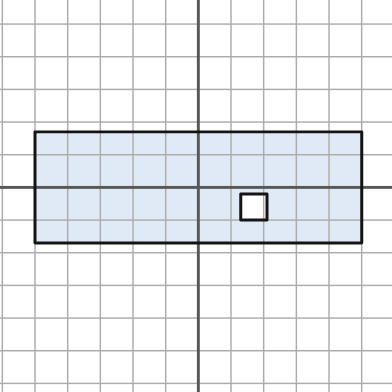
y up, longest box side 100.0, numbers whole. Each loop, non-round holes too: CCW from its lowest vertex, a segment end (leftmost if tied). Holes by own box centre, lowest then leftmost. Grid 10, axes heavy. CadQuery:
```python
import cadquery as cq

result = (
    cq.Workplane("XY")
    .moveTo(-50.0, -17.0)
    .lineTo(50.0, -17.0)
    .lineTo(50.0, 17.0)
    .lineTo(-50.0, 17.0)
    .close()
    .moveTo(13.0, -10.0)
    .lineTo(21.0, -10.0)
    .lineTo(21.0, -2.0)
    .lineTo(13.0, -2.0)
    .close()
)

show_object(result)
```